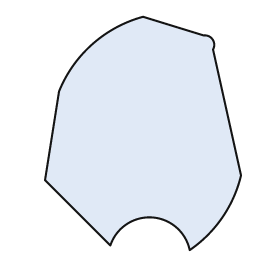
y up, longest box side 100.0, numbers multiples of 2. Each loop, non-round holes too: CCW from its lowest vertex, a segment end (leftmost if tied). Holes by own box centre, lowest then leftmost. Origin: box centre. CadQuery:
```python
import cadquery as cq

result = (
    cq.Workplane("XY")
    .moveTo(20.0, -50.0)
    .threePointArc((34.0, -36.0), (42.0, -18.0))
    .lineTo(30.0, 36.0)
    .threePointArc((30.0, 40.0), (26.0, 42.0))
    .lineTo(0.0, 50.0)
    .threePointArc((-22.0, 38.0), (-36.0, 18.0))
    .lineTo(-42.0, -20.0)
    .lineTo(-14.0, -48.0)
    .threePointArc((4.0, -36.0), (20.0, -50.0))
    .close()
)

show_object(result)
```